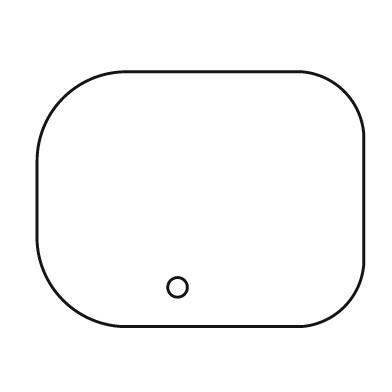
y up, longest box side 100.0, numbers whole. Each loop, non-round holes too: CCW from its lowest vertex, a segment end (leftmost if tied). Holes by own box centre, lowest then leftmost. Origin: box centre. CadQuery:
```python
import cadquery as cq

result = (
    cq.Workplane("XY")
    .moveTo(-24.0, -39.0)
    .lineTo(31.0, -39.0)
    .threePointArc((44.0, -33.0), (50.0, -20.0))
    .lineTo(50.0, 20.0)
    .threePointArc((44.0, 33.0), (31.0, 39.0))
    .lineTo(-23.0, 39.0)
    .threePointArc((-42.0, 31.0), (-50.0, 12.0))
    .lineTo(-50.0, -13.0)
    .threePointArc((-42.0, -31.0), (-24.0, -39.0))
    .close()
    .moveTo(-7.0, -27.0)
    .circle(3.0)
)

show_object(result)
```